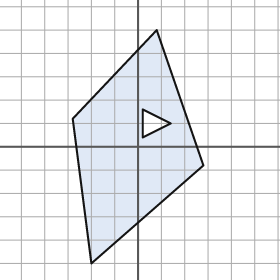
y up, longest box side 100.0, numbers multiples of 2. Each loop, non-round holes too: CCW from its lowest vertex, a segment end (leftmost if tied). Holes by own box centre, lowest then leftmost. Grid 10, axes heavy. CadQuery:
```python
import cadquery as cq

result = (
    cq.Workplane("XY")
    .moveTo(-20.0, -50.0)
    .lineTo(28.0, -8.0)
    .lineTo(8.0, 50.0)
    .lineTo(-28.0, 12.0)
    .close()
    .moveTo(2.0, 4.0)
    .lineTo(14.0, 10.0)
    .lineTo(2.0, 16.0)
    .close()
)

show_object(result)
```